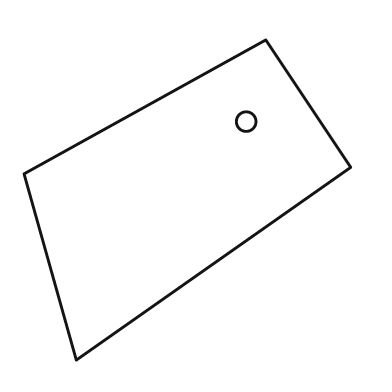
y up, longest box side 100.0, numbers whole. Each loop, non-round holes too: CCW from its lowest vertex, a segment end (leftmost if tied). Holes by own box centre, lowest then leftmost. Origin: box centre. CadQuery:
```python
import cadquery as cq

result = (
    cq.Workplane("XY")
    .moveTo(-34.0, -49.0)
    .lineTo(50.0, 10.0)
    .lineTo(24.0, 49.0)
    .lineTo(-50.0, 8.0)
    .close()
    .moveTo(18.0, 24.0)
    .circle(3.0)
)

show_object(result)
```